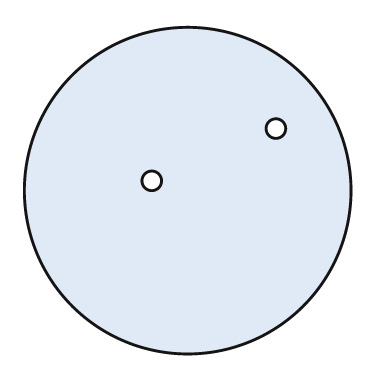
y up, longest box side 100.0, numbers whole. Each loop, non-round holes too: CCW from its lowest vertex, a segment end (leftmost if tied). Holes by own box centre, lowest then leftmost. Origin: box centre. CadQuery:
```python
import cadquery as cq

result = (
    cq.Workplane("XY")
    .moveTo(0.0, 0.0)
    .circle(50.0)
    .moveTo(-11.0, 3.0)
    .circle(3.0)
    .moveTo(27.0, 19.0)
    .circle(3.0)
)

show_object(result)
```